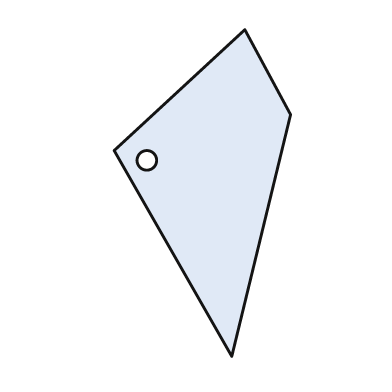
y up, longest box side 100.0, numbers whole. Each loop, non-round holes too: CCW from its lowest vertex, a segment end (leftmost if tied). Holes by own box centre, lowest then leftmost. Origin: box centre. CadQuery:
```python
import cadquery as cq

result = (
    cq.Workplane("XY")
    .moveTo(9.0, -50.0)
    .lineTo(27.0, 24.0)
    .lineTo(13.0, 50.0)
    .lineTo(-27.0, 13.0)
    .close()
    .moveTo(-17.0, 10.0)
    .circle(3.0)
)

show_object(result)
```